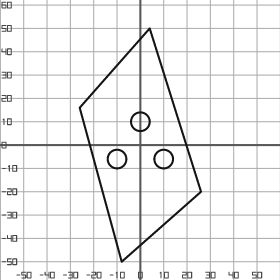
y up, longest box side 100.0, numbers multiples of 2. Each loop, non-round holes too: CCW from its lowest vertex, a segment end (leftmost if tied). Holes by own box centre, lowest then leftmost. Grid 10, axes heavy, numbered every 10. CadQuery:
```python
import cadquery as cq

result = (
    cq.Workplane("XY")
    .moveTo(-8.0, -50.0)
    .lineTo(26.0, -20.0)
    .lineTo(4.0, 50.0)
    .lineTo(-26.0, 16.0)
    .close()
    .moveTo(-10.0, -6.0)
    .circle(4.0)
    .moveTo(10.0, -6.0)
    .circle(4.0)
    .moveTo(0.0, 10.0)
    .circle(4.0)
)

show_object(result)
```